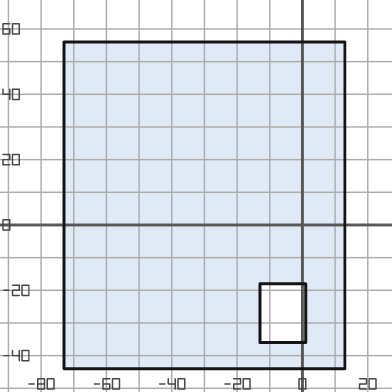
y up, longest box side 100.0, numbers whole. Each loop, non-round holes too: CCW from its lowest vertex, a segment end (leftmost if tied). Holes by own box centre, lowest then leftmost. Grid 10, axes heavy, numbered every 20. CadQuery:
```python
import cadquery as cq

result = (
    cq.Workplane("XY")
    .moveTo(-73.0, -44.0)
    .lineTo(13.0, -44.0)
    .lineTo(13.0, 56.0)
    .lineTo(-73.0, 56.0)
    .close()
    .moveTo(-13.0, -36.0)
    .lineTo(1.0, -36.0)
    .lineTo(1.0, -18.0)
    .lineTo(-13.0, -18.0)
    .close()
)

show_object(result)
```